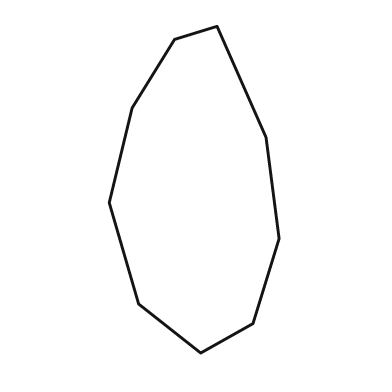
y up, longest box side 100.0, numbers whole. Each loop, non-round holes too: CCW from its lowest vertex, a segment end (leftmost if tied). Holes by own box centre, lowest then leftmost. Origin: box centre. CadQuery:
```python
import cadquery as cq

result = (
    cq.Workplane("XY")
    .moveTo(2.0, -50.0)
    .lineTo(18.0, -41.0)
    .lineTo(26.0, -15.0)
    .lineTo(22.0, 16.0)
    .lineTo(7.0, 50.0)
    .lineTo(-6.0, 46.0)
    .lineTo(-19.0, 25.0)
    .lineTo(-26.0, -4.0)
    .lineTo(-17.0, -35.0)
    .close()
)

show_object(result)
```